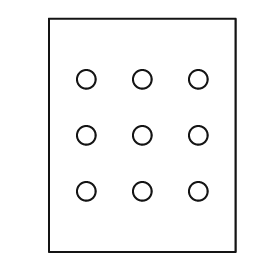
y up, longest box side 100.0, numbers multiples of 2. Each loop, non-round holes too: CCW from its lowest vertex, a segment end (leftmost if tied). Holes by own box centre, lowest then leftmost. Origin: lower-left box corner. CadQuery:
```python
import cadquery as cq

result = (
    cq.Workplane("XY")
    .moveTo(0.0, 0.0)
    .lineTo(80.0, 0.0)
    .lineTo(80.0, 100.0)
    .lineTo(0.0, 100.0)
    .close()
    .moveTo(16.0, 26.0)
    .circle(4.0)
    .moveTo(40.0, 26.0)
    .circle(4.0)
    .moveTo(64.0, 26.0)
    .circle(4.0)
    .moveTo(16.0, 50.0)
    .circle(4.0)
    .moveTo(40.0, 50.0)
    .circle(4.0)
    .moveTo(64.0, 50.0)
    .circle(4.0)
    .moveTo(16.0, 74.0)
    .circle(4.0)
    .moveTo(40.0, 74.0)
    .circle(4.0)
    .moveTo(64.0, 74.0)
    .circle(4.0)
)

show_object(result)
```